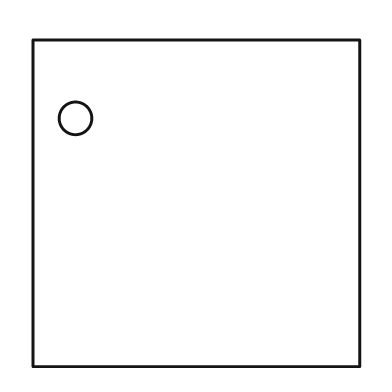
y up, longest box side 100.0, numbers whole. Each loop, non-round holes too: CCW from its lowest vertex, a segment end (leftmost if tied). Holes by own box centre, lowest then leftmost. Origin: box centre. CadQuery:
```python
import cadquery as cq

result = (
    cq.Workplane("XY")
    .moveTo(-50.0, -50.0)
    .lineTo(50.0, -50.0)
    .lineTo(50.0, 50.0)
    .lineTo(-50.0, 50.0)
    .close()
    .moveTo(-37.0, 26.0)
    .circle(5.0)
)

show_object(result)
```